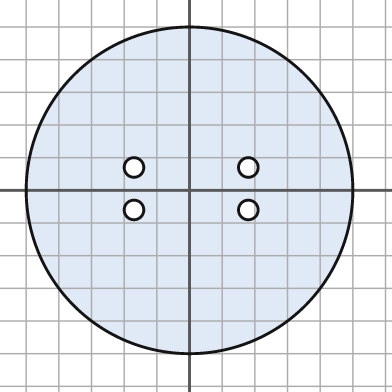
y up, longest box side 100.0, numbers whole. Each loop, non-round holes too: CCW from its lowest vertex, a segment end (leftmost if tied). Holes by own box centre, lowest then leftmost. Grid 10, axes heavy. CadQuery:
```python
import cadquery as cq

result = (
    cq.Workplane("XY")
    .moveTo(0.0, 0.0)
    .circle(50.0)
    .moveTo(-17.0, -6.0)
    .circle(3.0)
    .moveTo(18.0, -6.0)
    .circle(3.0)
    .moveTo(-17.0, 7.0)
    .circle(3.0)
    .moveTo(18.0, 7.0)
    .circle(3.0)
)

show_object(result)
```